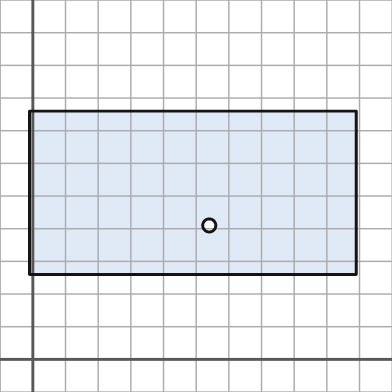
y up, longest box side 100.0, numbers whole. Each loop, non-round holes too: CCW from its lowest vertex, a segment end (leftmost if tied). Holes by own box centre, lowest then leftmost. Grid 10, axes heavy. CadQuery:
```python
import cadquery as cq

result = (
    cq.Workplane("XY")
    .moveTo(-1.0, 26.0)
    .lineTo(99.0, 26.0)
    .lineTo(99.0, 76.0)
    .lineTo(-1.0, 76.0)
    .close()
    .moveTo(54.0, 41.0)
    .circle(2.0)
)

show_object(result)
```